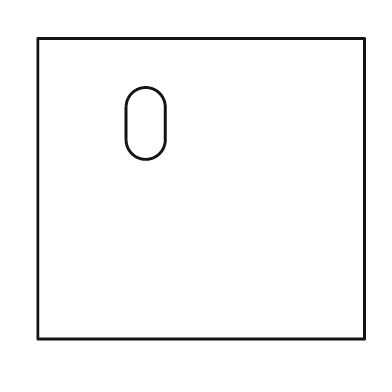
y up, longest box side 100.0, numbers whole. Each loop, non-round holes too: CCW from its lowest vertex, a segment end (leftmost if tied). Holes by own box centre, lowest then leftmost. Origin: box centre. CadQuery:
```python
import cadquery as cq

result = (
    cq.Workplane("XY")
    .moveTo(-50.0, -46.0)
    .lineTo(50.0, -46.0)
    .lineTo(50.0, 46.0)
    .lineTo(-50.0, 46.0)
    .close()
    .moveTo(-23.0, 15.0)
    .threePointArc((-17.0, 9.0), (-11.0, 15.0))
    .lineTo(-11.0, 25.0)
    .threePointArc((-17.0, 31.0), (-23.0, 25.0))
    .close()
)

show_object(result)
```